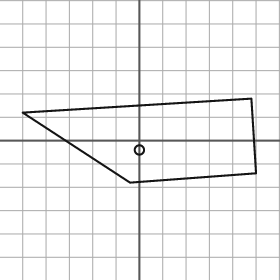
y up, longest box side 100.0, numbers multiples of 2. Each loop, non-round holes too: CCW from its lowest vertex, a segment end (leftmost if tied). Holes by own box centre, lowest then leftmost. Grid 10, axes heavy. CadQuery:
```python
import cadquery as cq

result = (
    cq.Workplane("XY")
    .moveTo(-4.0, -18.0)
    .lineTo(50.0, -14.0)
    .lineTo(48.0, 18.0)
    .lineTo(-50.0, 12.0)
    .close()
    .moveTo(0.0, -4.0)
    .circle(2.0)
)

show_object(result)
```